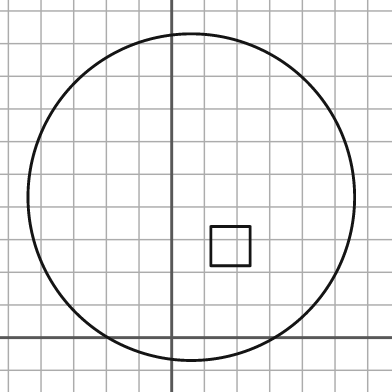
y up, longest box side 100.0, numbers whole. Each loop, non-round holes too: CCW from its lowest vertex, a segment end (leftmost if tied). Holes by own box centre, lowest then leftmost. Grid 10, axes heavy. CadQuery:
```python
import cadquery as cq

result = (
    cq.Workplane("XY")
    .moveTo(6.0, 43.0)
    .circle(50.0)
    .moveTo(12.0, 22.0)
    .lineTo(24.0, 22.0)
    .lineTo(24.0, 34.0)
    .lineTo(12.0, 34.0)
    .close()
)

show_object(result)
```